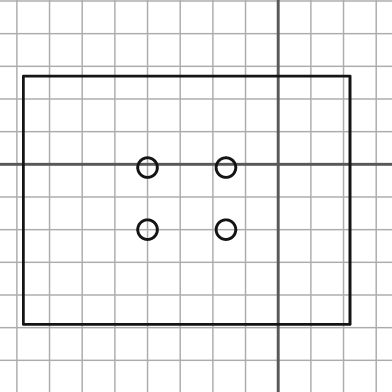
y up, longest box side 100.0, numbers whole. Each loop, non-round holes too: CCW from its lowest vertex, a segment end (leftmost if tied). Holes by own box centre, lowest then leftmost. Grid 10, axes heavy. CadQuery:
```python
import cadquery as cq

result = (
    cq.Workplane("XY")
    .moveTo(-78.0, -49.0)
    .lineTo(22.0, -49.0)
    .lineTo(22.0, 27.0)
    .lineTo(-78.0, 27.0)
    .close()
    .moveTo(-40.0, -20.0)
    .circle(3.0)
    .moveTo(-16.0, -20.0)
    .circle(3.0)
    .moveTo(-40.0, -1.0)
    .circle(3.0)
    .moveTo(-16.0, -1.0)
    .circle(3.0)
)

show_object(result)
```